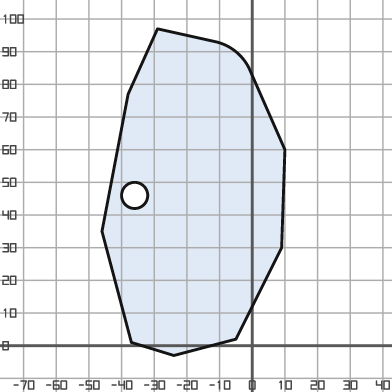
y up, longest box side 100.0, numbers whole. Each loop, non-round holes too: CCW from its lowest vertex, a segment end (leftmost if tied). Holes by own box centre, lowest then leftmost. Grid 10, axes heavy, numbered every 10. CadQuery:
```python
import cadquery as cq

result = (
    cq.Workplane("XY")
    .moveTo(-24.0, -3.0)
    .lineTo(-5.0, 2.0)
    .lineTo(9.0, 30.0)
    .lineTo(10.0, 60.0)
    .lineTo(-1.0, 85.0)
    .threePointArc((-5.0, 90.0), (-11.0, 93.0))
    .lineTo(-29.0, 97.0)
    .lineTo(-38.0, 77.0)
    .lineTo(-46.0, 35.0)
    .lineTo(-37.0, 1.0)
    .close()
    .moveTo(-36.0, 46.0)
    .circle(4.0)
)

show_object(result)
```